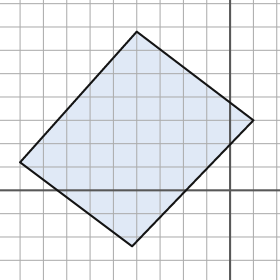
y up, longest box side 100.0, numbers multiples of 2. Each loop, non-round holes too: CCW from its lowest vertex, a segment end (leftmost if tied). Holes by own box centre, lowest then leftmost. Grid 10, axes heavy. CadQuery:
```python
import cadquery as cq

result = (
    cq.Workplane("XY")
    .moveTo(-42.0, -24.0)
    .lineTo(10.0, 30.0)
    .lineTo(-40.0, 68.0)
    .lineTo(-90.0, 12.0)
    .close()
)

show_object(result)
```